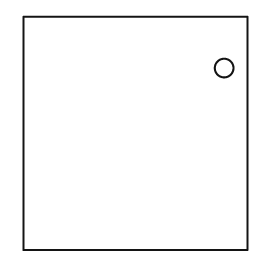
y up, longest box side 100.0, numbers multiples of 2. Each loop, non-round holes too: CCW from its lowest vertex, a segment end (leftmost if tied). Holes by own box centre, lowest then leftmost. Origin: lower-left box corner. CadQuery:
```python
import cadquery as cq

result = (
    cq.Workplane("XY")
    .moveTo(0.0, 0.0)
    .lineTo(96.0, 0.0)
    .lineTo(96.0, 100.0)
    .lineTo(0.0, 100.0)
    .close()
    .moveTo(86.0, 78.0)
    .circle(4.0)
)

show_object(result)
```